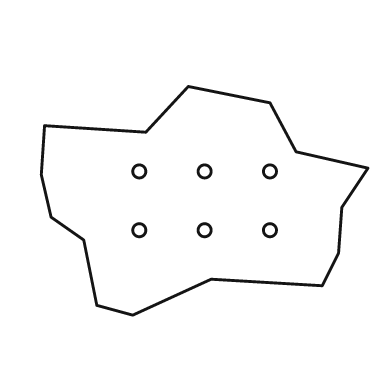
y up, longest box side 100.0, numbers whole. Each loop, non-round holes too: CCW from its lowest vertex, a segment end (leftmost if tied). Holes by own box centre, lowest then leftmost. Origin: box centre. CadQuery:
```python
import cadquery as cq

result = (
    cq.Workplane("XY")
    .moveTo(-22.0, -35.0)
    .lineTo(2.0, -24.0)
    .lineTo(36.0, -26.0)
    .lineTo(41.0, -16.0)
    .lineTo(42.0, -2.0)
    .lineTo(50.0, 10.0)
    .lineTo(28.0, 15.0)
    .lineTo(20.0, 30.0)
    .lineTo(-5.0, 35.0)
    .lineTo(-18.0, 21.0)
    .lineTo(-49.0, 23.0)
    .lineTo(-50.0, 8.0)
    .lineTo(-47.0, -5.0)
    .lineTo(-37.0, -12.0)
    .lineTo(-33.0, -32.0)
    .close()
    .moveTo(-20.0, -9.0)
    .circle(2.0)
    .moveTo(0.0, -9.0)
    .circle(2.0)
    .moveTo(20.0, -9.0)
    .circle(2.0)
    .moveTo(-20.0, 9.0)
    .circle(2.0)
    .moveTo(0.0, 9.0)
    .circle(2.0)
    .moveTo(20.0, 9.0)
    .circle(2.0)
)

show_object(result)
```